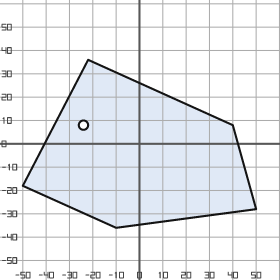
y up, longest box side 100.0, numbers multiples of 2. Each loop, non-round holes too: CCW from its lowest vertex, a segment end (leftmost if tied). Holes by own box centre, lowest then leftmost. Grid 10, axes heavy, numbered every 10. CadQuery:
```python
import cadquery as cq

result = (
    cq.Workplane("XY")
    .moveTo(-10.0, -36.0)
    .lineTo(50.0, -28.0)
    .lineTo(40.0, 8.0)
    .lineTo(-22.0, 36.0)
    .lineTo(-50.0, -18.0)
    .close()
    .moveTo(-24.0, 8.0)
    .circle(2.0)
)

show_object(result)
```